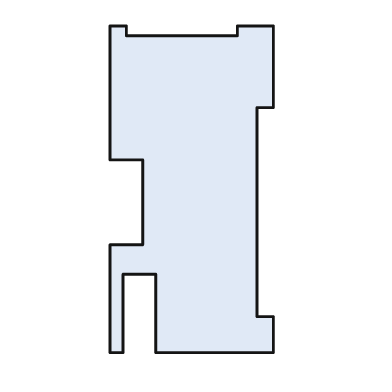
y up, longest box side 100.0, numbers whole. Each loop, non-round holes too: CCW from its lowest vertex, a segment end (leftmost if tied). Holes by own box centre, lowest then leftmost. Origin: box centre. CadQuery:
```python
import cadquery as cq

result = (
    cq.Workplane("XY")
    .moveTo(-25.0, -50.0)
    .lineTo(-21.0, -50.0)
    .lineTo(-21.0, -26.0)
    .lineTo(-11.0, -26.0)
    .lineTo(-11.0, -50.0)
    .lineTo(25.0, -50.0)
    .lineTo(25.0, -39.0)
    .lineTo(20.0, -39.0)
    .lineTo(20.0, 25.0)
    .lineTo(25.0, 25.0)
    .lineTo(25.0, 50.0)
    .lineTo(14.0, 50.0)
    .lineTo(14.0, 47.0)
    .lineTo(-20.0, 47.0)
    .lineTo(-20.0, 50.0)
    .lineTo(-25.0, 50.0)
    .lineTo(-25.0, 9.0)
    .lineTo(-15.0, 9.0)
    .lineTo(-15.0, -17.0)
    .lineTo(-25.0, -17.0)
    .close()
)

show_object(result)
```